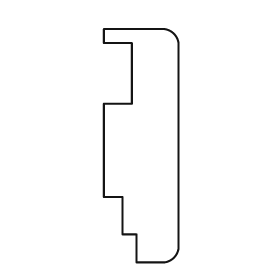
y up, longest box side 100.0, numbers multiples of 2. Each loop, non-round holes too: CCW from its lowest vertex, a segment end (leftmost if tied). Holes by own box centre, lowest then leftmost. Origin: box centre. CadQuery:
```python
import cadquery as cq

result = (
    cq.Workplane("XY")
    .moveTo(-2.0, -50.0)
    .lineTo(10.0, -50.0)
    .threePointArc((14.0, -48.0), (16.0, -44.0))
    .lineTo(16.0, 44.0)
    .threePointArc((14.0, 48.0), (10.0, 50.0))
    .lineTo(-16.0, 50.0)
    .lineTo(-16.0, 44.0)
    .lineTo(-4.0, 44.0)
    .lineTo(-4.0, 18.0)
    .lineTo(-16.0, 18.0)
    .lineTo(-16.0, -22.0)
    .lineTo(-8.0, -22.0)
    .lineTo(-8.0, -38.0)
    .lineTo(-2.0, -38.0)
    .close()
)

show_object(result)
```